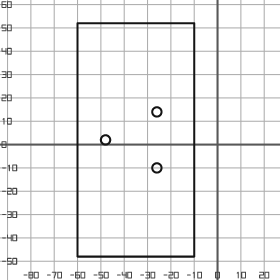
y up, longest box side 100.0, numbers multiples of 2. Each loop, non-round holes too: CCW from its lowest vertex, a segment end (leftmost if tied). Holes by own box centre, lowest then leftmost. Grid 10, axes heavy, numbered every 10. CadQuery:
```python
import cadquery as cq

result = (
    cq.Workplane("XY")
    .moveTo(-60.0, -48.0)
    .lineTo(-10.0, -48.0)
    .lineTo(-10.0, 52.0)
    .lineTo(-60.0, 52.0)
    .close()
    .moveTo(-26.0, -10.0)
    .circle(2.0)
    .moveTo(-48.0, 2.0)
    .circle(2.0)
    .moveTo(-26.0, 14.0)
    .circle(2.0)
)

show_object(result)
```